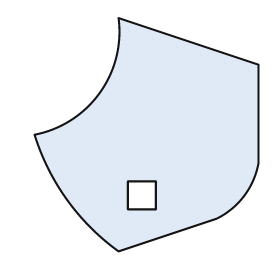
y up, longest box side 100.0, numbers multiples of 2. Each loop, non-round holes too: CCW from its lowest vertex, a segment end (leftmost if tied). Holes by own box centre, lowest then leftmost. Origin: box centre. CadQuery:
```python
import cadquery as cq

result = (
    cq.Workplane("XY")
    .moveTo(-12.0, -50.0)
    .lineTo(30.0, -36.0)
    .threePointArc((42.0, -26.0), (48.0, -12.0))
    .lineTo(48.0, 30.0)
    .lineTo(-12.0, 50.0)
    .threePointArc((-20.0, 18.0), (-48.0, 0.0))
    .threePointArc((-34.0, -28.0), (-12.0, -50.0))
    .close()
    .moveTo(-8.0, -32.0)
    .lineTo(4.0, -32.0)
    .lineTo(4.0, -20.0)
    .lineTo(-8.0, -20.0)
    .close()
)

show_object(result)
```